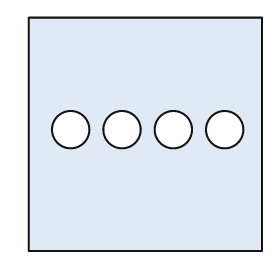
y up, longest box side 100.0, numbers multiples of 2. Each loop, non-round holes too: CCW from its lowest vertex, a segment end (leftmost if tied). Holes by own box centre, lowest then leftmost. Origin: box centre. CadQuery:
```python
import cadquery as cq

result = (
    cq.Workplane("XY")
    .moveTo(-50.0, -50.0)
    .lineTo(50.0, -50.0)
    .lineTo(50.0, 50.0)
    .lineTo(-50.0, 50.0)
    .close()
    .moveTo(-32.0, 2.0)
    .circle(8.0)
    .moveTo(-10.0, 2.0)
    .circle(8.0)
    .moveTo(12.0, 2.0)
    .circle(8.0)
    .moveTo(34.0, 2.0)
    .circle(8.0)
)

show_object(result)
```